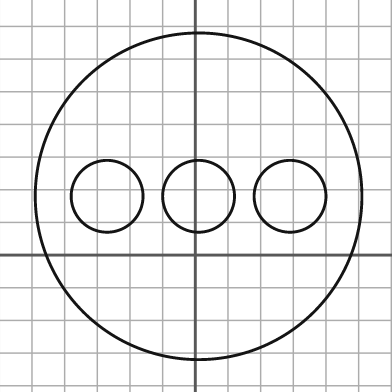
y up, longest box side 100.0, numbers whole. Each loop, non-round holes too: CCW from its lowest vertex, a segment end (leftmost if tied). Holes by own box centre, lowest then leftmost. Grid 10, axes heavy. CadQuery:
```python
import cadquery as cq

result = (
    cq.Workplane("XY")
    .moveTo(1.0, 18.0)
    .circle(50.0)
    .moveTo(-27.0, 18.0)
    .circle(11.0)
    .moveTo(1.0, 18.0)
    .circle(11.0)
    .moveTo(29.0, 18.0)
    .circle(11.0)
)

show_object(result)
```